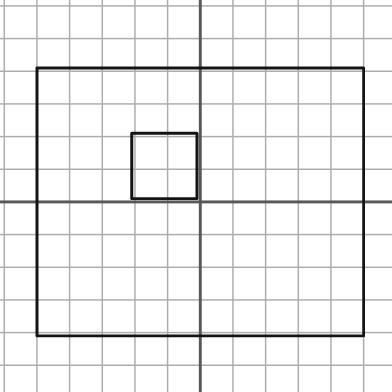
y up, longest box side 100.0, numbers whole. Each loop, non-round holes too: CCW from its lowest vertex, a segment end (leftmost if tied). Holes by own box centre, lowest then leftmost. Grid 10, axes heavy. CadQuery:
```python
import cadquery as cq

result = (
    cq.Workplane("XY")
    .moveTo(-50.0, -41.0)
    .lineTo(50.0, -41.0)
    .lineTo(50.0, 41.0)
    .lineTo(-50.0, 41.0)
    .close()
    .moveTo(-21.0, 1.0)
    .lineTo(-1.0, 1.0)
    .lineTo(-1.0, 21.0)
    .lineTo(-21.0, 21.0)
    .close()
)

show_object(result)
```